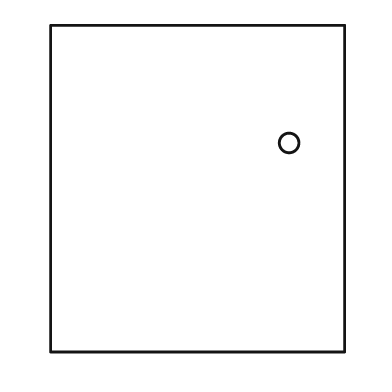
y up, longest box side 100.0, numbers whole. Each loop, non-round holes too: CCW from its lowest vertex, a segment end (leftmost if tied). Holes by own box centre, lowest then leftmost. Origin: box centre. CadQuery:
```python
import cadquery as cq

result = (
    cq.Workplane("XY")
    .moveTo(-45.0, -50.0)
    .lineTo(45.0, -50.0)
    .lineTo(45.0, 50.0)
    .lineTo(-45.0, 50.0)
    .close()
    .moveTo(28.0, 14.0)
    .circle(3.0)
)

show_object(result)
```